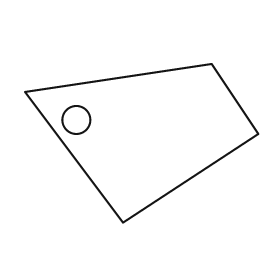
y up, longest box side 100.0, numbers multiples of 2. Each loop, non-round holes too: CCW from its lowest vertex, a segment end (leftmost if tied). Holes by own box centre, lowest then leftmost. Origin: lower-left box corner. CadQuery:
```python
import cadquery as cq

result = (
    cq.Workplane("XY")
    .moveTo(42.0, 0.0)
    .lineTo(100.0, 38.0)
    .lineTo(80.0, 68.0)
    .lineTo(0.0, 56.0)
    .close()
    .moveTo(22.0, 44.0)
    .circle(6.0)
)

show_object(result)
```